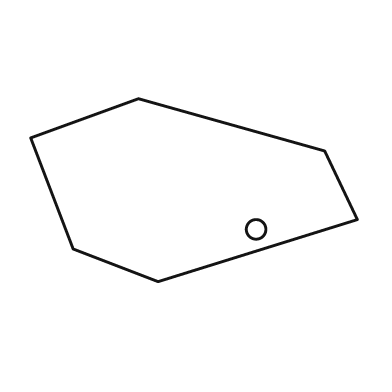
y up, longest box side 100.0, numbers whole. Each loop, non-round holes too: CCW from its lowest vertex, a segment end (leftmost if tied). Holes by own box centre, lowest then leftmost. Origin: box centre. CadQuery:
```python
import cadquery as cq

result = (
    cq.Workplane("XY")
    .moveTo(-11.0, -28.0)
    .lineTo(50.0, -9.0)
    .lineTo(40.0, 12.0)
    .lineTo(-17.0, 28.0)
    .lineTo(-50.0, 16.0)
    .lineTo(-37.0, -18.0)
    .close()
    .moveTo(19.0, -12.0)
    .circle(3.0)
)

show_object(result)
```